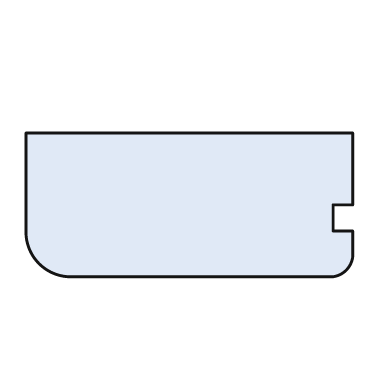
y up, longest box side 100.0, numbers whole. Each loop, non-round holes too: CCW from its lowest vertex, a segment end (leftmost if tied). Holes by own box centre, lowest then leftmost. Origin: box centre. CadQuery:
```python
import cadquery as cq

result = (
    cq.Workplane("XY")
    .moveTo(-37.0, -22.0)
    .lineTo(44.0, -22.0)
    .threePointArc((48.0, -20.0), (50.0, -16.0))
    .lineTo(50.0, -8.0)
    .lineTo(44.0, -8.0)
    .lineTo(44.0, 0.0)
    .lineTo(50.0, 0.0)
    .lineTo(50.0, 22.0)
    .lineTo(-50.0, 22.0)
    .lineTo(-50.0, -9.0)
    .threePointArc((-46.0, -18.0), (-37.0, -22.0))
    .close()
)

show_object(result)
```